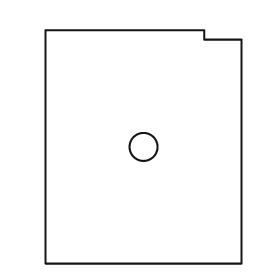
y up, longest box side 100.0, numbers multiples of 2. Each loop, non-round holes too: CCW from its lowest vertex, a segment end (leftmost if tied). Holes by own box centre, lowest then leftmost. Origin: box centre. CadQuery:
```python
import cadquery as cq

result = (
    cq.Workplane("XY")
    .moveTo(-42.0, -50.0)
    .lineTo(42.0, -50.0)
    .lineTo(42.0, 46.0)
    .lineTo(26.0, 46.0)
    .lineTo(26.0, 50.0)
    .lineTo(-42.0, 50.0)
    .close()
    .moveTo(0.0, 0.0)
    .circle(6.0)
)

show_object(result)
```